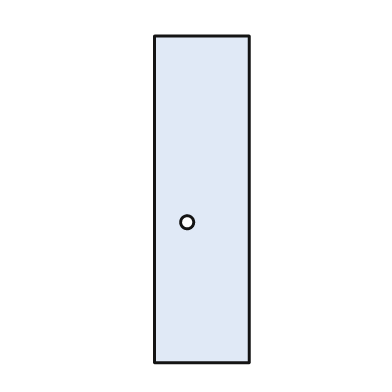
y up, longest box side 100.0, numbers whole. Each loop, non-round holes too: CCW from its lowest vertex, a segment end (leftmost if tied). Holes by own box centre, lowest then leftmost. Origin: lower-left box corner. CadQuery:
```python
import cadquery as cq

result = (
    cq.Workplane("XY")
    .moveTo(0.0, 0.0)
    .lineTo(29.0, 0.0)
    .lineTo(29.0, 100.0)
    .lineTo(0.0, 100.0)
    .close()
    .moveTo(10.0, 43.0)
    .circle(2.0)
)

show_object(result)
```